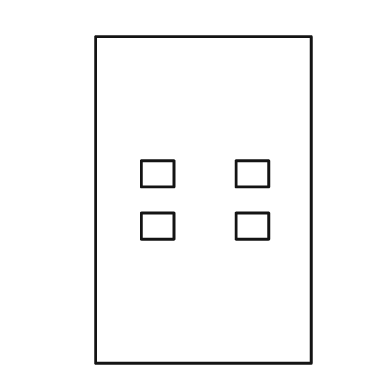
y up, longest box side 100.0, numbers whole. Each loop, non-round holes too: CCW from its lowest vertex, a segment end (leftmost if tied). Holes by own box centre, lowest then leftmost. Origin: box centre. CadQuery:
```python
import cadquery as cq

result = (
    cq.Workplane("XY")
    .moveTo(-33.0, -50.0)
    .lineTo(33.0, -50.0)
    .lineTo(33.0, 50.0)
    .lineTo(-33.0, 50.0)
    .close()
    .moveTo(-19.0, -12.0)
    .lineTo(-9.0, -12.0)
    .lineTo(-9.0, -4.0)
    .lineTo(-19.0, -4.0)
    .close()
    .moveTo(10.0, -12.0)
    .lineTo(20.0, -12.0)
    .lineTo(20.0, -4.0)
    .lineTo(10.0, -4.0)
    .close()
    .moveTo(-19.0, 4.0)
    .lineTo(-9.0, 4.0)
    .lineTo(-9.0, 12.0)
    .lineTo(-19.0, 12.0)
    .close()
    .moveTo(10.0, 4.0)
    .lineTo(20.0, 4.0)
    .lineTo(20.0, 12.0)
    .lineTo(10.0, 12.0)
    .close()
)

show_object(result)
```